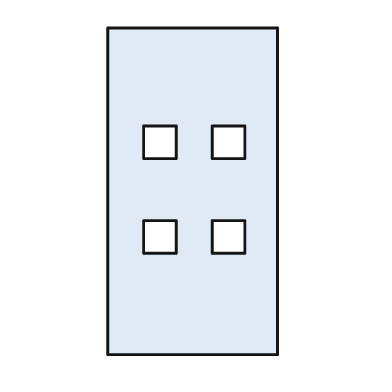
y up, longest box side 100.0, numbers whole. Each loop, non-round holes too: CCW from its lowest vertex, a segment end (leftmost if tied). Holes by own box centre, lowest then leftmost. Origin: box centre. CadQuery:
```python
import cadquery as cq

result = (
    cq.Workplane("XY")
    .moveTo(-26.0, -50.0)
    .lineTo(26.0, -50.0)
    .lineTo(26.0, 50.0)
    .lineTo(-26.0, 50.0)
    .close()
    .moveTo(-15.0, -19.0)
    .lineTo(-5.0, -19.0)
    .lineTo(-5.0, -9.0)
    .lineTo(-15.0, -9.0)
    .close()
    .moveTo(6.0, -19.0)
    .lineTo(16.0, -19.0)
    .lineTo(16.0, -9.0)
    .lineTo(6.0, -9.0)
    .close()
    .moveTo(-15.0, 10.0)
    .lineTo(-5.0, 10.0)
    .lineTo(-5.0, 20.0)
    .lineTo(-15.0, 20.0)
    .close()
    .moveTo(6.0, 10.0)
    .lineTo(16.0, 10.0)
    .lineTo(16.0, 20.0)
    .lineTo(6.0, 20.0)
    .close()
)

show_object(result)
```